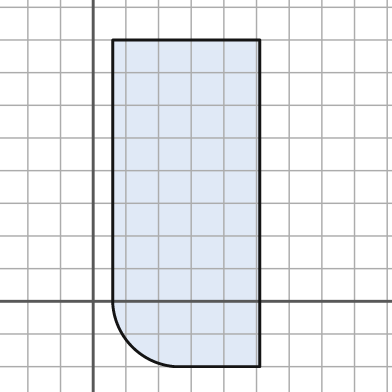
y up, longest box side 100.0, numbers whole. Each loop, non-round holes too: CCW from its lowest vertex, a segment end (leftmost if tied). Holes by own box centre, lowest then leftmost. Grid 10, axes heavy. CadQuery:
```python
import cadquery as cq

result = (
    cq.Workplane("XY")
    .moveTo(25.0, -20.0)
    .lineTo(51.0, -20.0)
    .lineTo(51.0, 80.0)
    .lineTo(6.0, 80.0)
    .lineTo(6.0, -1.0)
    .threePointArc((12.0, -14.0), (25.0, -20.0))
    .close()
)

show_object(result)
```